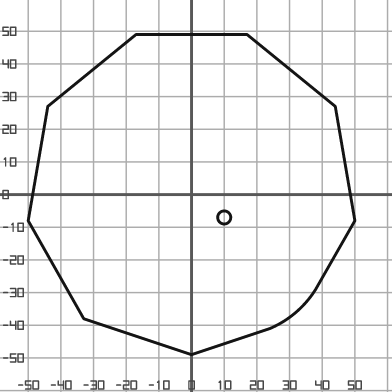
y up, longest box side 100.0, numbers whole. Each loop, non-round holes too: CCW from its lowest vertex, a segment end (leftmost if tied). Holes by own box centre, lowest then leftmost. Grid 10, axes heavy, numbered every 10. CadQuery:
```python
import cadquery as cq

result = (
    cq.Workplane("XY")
    .moveTo(0.0, -49.0)
    .lineTo(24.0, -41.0)
    .threePointArc((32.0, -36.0), (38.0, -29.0))
    .lineTo(50.0, -8.0)
    .lineTo(44.0, 27.0)
    .lineTo(17.0, 49.0)
    .lineTo(-17.0, 49.0)
    .lineTo(-44.0, 27.0)
    .lineTo(-50.0, -8.0)
    .lineTo(-33.0, -38.0)
    .close()
    .moveTo(10.0, -7.0)
    .circle(2.0)
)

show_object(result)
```